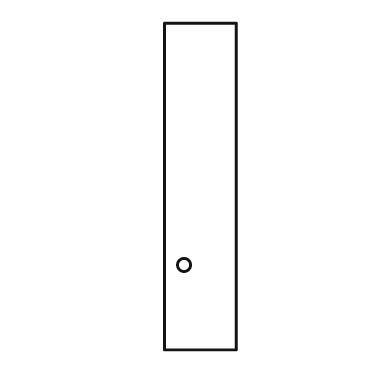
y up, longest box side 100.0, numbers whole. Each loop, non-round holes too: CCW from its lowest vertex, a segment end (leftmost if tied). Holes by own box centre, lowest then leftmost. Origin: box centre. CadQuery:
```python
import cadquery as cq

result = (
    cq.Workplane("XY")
    .moveTo(-11.0, -50.0)
    .lineTo(11.0, -50.0)
    .lineTo(11.0, 50.0)
    .lineTo(-11.0, 50.0)
    .close()
    .moveTo(-5.0, -24.0)
    .circle(2.0)
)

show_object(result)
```